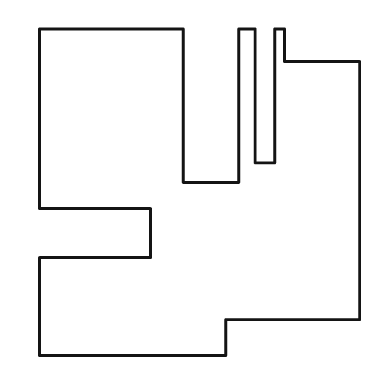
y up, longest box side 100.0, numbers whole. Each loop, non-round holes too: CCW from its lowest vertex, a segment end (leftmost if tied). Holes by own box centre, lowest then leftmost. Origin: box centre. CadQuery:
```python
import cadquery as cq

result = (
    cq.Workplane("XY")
    .moveTo(-49.0, -50.0)
    .lineTo(8.0, -50.0)
    .lineTo(8.0, -39.0)
    .lineTo(49.0, -39.0)
    .lineTo(49.0, 40.0)
    .lineTo(26.0, 40.0)
    .lineTo(26.0, 50.0)
    .lineTo(23.0, 50.0)
    .lineTo(23.0, 9.0)
    .lineTo(17.0, 9.0)
    .lineTo(17.0, 50.0)
    .lineTo(12.0, 50.0)
    .lineTo(12.0, 3.0)
    .lineTo(-5.0, 3.0)
    .lineTo(-5.0, 50.0)
    .lineTo(-49.0, 50.0)
    .lineTo(-49.0, -5.0)
    .lineTo(-15.0, -5.0)
    .lineTo(-15.0, -20.0)
    .lineTo(-49.0, -20.0)
    .close()
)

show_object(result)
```